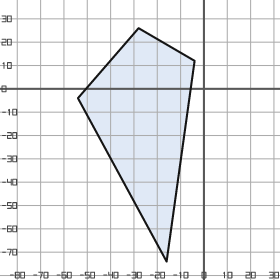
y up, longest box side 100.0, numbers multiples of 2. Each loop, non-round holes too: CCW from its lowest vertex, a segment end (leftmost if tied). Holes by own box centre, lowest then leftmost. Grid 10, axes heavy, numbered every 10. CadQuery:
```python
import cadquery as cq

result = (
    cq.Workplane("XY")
    .moveTo(-16.0, -74.0)
    .lineTo(-4.0, 12.0)
    .lineTo(-28.0, 26.0)
    .lineTo(-54.0, -4.0)
    .close()
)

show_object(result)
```